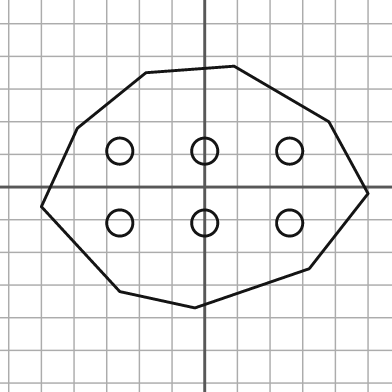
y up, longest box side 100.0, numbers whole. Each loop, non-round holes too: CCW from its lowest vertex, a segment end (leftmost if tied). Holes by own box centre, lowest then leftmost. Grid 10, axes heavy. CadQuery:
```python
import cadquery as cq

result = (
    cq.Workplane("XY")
    .moveTo(-3.0, -37.0)
    .lineTo(32.0, -25.0)
    .lineTo(50.0, -2.0)
    .lineTo(38.0, 20.0)
    .lineTo(9.0, 37.0)
    .lineTo(-18.0, 35.0)
    .lineTo(-39.0, 18.0)
    .lineTo(-50.0, -6.0)
    .lineTo(-26.0, -32.0)
    .close()
    .moveTo(-26.0, -11.0)
    .circle(4.0)
    .moveTo(0.0, -11.0)
    .circle(4.0)
    .moveTo(26.0, -11.0)
    .circle(4.0)
    .moveTo(-26.0, 11.0)
    .circle(4.0)
    .moveTo(0.0, 11.0)
    .circle(4.0)
    .moveTo(26.0, 11.0)
    .circle(4.0)
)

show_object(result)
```